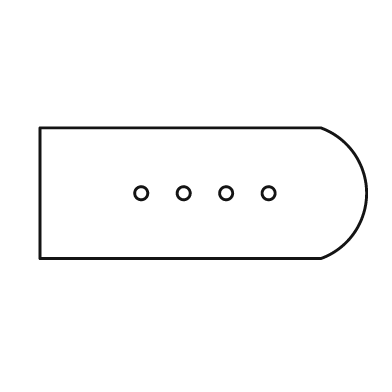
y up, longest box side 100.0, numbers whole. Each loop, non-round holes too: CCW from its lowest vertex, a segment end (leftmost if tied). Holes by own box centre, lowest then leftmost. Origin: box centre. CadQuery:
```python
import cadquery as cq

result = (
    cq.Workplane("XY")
    .moveTo(-50.0, -20.0)
    .lineTo(36.0, -20.0)
    .threePointArc((50.0, 0.0), (36.0, 20.0))
    .lineTo(-50.0, 20.0)
    .close()
    .moveTo(-19.0, 0.0)
    .circle(2.0)
    .moveTo(-6.0, 0.0)
    .circle(2.0)
    .moveTo(7.0, 0.0)
    .circle(2.0)
    .moveTo(20.0, 0.0)
    .circle(2.0)
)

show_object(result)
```